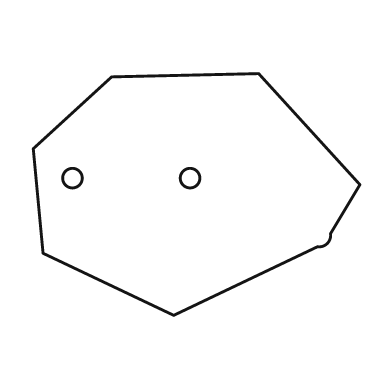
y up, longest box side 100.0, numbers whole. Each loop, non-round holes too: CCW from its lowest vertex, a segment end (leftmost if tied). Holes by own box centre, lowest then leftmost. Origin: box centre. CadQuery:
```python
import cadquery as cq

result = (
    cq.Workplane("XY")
    .moveTo(-7.0, -37.0)
    .lineTo(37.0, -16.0)
    .threePointArc((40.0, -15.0), (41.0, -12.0))
    .lineTo(50.0, 3.0)
    .lineTo(19.0, 37.0)
    .lineTo(-26.0, 36.0)
    .lineTo(-50.0, 14.0)
    .lineTo(-47.0, -18.0)
    .close()
    .moveTo(-38.0, 5.0)
    .circle(3.0)
    .moveTo(-2.0, 5.0)
    .circle(3.0)
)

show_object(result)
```